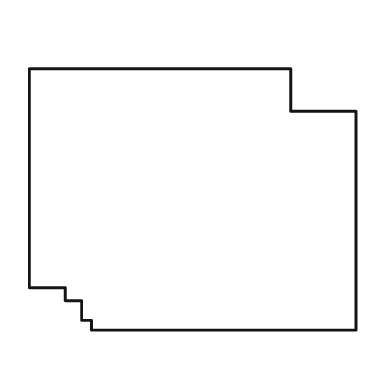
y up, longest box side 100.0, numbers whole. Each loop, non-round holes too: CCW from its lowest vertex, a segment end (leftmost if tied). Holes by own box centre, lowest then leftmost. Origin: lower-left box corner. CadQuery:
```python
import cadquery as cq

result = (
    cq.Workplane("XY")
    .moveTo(19.0, 0.0)
    .lineTo(100.0, 0.0)
    .lineTo(100.0, 67.0)
    .lineTo(80.0, 67.0)
    .lineTo(80.0, 80.0)
    .lineTo(0.0, 80.0)
    .lineTo(0.0, 13.0)
    .lineTo(11.0, 13.0)
    .lineTo(11.0, 9.0)
    .lineTo(16.0, 9.0)
    .lineTo(16.0, 3.0)
    .lineTo(19.0, 3.0)
    .close()
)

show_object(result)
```